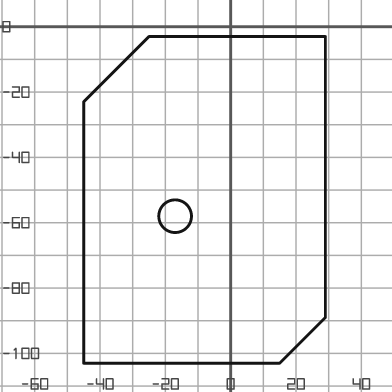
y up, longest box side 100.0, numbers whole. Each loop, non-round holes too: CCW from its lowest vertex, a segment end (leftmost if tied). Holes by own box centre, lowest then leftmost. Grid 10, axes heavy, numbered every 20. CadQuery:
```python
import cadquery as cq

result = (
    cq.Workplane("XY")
    .moveTo(-45.0, -103.0)
    .lineTo(15.0, -103.0)
    .lineTo(29.0, -89.0)
    .lineTo(29.0, -3.0)
    .lineTo(-25.0, -3.0)
    .lineTo(-45.0, -23.0)
    .close()
    .moveTo(-17.0, -58.0)
    .circle(5.0)
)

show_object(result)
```